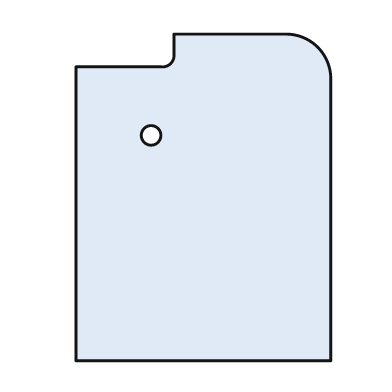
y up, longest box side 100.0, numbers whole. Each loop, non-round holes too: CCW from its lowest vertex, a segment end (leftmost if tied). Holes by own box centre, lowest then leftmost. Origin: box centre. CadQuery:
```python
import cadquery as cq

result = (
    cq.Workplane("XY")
    .moveTo(-39.0, -50.0)
    .lineTo(39.0, -50.0)
    .lineTo(39.0, 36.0)
    .threePointArc((35.0, 46.0), (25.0, 50.0))
    .lineTo(-9.0, 50.0)
    .lineTo(-9.0, 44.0)
    .threePointArc((-10.0, 41.0), (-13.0, 40.0))
    .lineTo(-39.0, 40.0)
    .close()
    .moveTo(-16.0, 19.0)
    .circle(3.0)
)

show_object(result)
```